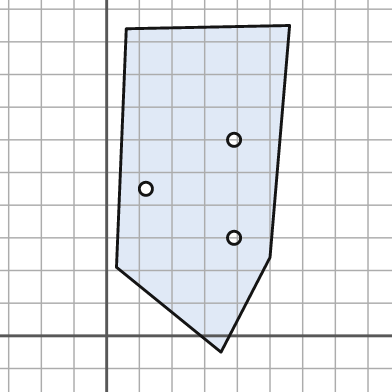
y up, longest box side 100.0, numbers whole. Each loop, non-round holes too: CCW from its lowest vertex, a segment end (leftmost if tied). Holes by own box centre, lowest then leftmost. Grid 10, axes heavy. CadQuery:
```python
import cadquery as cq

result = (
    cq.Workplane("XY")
    .moveTo(35.0, -5.0)
    .lineTo(50.0, 24.0)
    .lineTo(56.0, 95.0)
    .lineTo(6.0, 94.0)
    .lineTo(3.0, 21.0)
    .close()
    .moveTo(39.0, 30.0)
    .circle(2.0)
    .moveTo(12.0, 45.0)
    .circle(2.0)
    .moveTo(39.0, 60.0)
    .circle(2.0)
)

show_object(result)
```